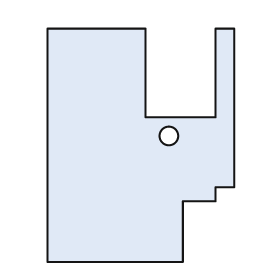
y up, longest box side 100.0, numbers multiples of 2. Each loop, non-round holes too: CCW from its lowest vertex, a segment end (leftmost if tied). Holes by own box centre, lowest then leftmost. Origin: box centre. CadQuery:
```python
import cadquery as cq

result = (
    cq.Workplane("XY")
    .moveTo(-40.0, -50.0)
    .lineTo(18.0, -50.0)
    .lineTo(18.0, -24.0)
    .lineTo(32.0, -24.0)
    .lineTo(32.0, -18.0)
    .lineTo(40.0, -18.0)
    .lineTo(40.0, 50.0)
    .lineTo(32.0, 50.0)
    .lineTo(32.0, 12.0)
    .lineTo(2.0, 12.0)
    .lineTo(2.0, 50.0)
    .lineTo(-40.0, 50.0)
    .close()
    .moveTo(12.0, 4.0)
    .circle(4.0)
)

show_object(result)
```